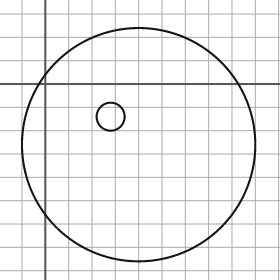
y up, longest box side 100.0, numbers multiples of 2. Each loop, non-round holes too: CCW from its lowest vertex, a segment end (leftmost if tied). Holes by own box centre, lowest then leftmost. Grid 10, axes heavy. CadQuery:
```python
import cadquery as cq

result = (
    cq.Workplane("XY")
    .moveTo(40.0, -26.0)
    .circle(50.0)
    .moveTo(28.0, -14.0)
    .circle(6.0)
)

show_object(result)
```